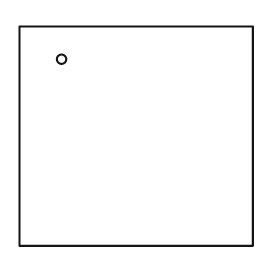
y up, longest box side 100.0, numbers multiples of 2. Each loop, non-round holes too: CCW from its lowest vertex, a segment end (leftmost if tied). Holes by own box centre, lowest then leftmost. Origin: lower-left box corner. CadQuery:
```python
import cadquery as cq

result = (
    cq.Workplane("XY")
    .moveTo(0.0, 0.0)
    .lineTo(100.0, 0.0)
    .lineTo(100.0, 94.0)
    .lineTo(0.0, 94.0)
    .close()
    .moveTo(18.0, 80.0)
    .circle(2.0)
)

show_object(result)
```